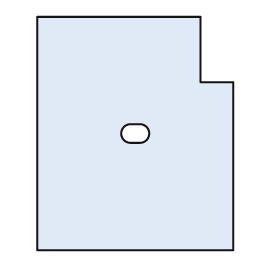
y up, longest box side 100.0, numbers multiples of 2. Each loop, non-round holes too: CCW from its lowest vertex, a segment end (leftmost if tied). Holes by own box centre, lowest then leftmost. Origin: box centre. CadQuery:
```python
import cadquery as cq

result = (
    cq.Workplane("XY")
    .moveTo(-42.0, -50.0)
    .lineTo(42.0, -50.0)
    .lineTo(42.0, 22.0)
    .lineTo(28.0, 22.0)
    .lineTo(28.0, 50.0)
    .lineTo(-42.0, 50.0)
    .close()
    .moveTo(-2.0, -4.0)
    .lineTo(2.0, -4.0)
    .threePointArc((6.0, 0.0), (2.0, 4.0))
    .lineTo(-2.0, 4.0)
    .threePointArc((-6.0, 0.0), (-2.0, -4.0))
    .close()
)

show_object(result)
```